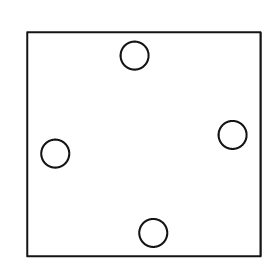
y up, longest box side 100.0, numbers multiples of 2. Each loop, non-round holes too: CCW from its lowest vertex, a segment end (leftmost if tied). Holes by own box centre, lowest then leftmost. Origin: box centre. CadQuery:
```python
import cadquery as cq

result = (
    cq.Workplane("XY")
    .moveTo(-50.0, -48.0)
    .lineTo(50.0, -48.0)
    .lineTo(50.0, 48.0)
    .lineTo(-50.0, 48.0)
    .close()
    .moveTo(4.0, -38.0)
    .circle(6.0)
    .moveTo(-38.0, -4.0)
    .circle(6.0)
    .moveTo(38.0, 4.0)
    .circle(6.0)
    .moveTo(-4.0, 38.0)
    .circle(6.0)
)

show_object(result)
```